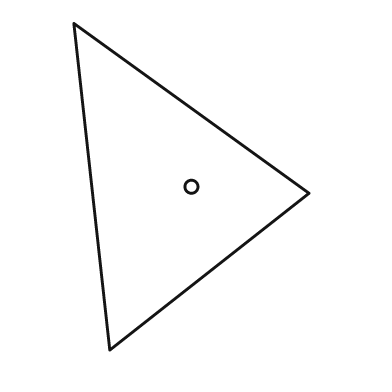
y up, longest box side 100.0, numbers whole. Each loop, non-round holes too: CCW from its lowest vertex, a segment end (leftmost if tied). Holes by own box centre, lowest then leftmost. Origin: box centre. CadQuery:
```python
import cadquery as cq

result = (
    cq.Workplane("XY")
    .moveTo(-25.0, -50.0)
    .lineTo(36.0, -2.0)
    .lineTo(-36.0, 50.0)
    .close()
    .moveTo(0.0, 0.0)
    .circle(2.0)
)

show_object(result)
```